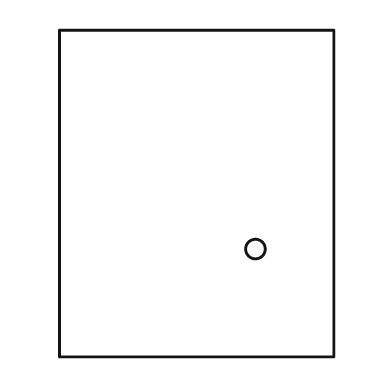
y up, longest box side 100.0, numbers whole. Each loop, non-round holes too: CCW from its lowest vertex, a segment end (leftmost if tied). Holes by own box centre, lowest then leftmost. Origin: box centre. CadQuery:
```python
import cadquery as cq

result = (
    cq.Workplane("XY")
    .moveTo(-42.0, -50.0)
    .lineTo(42.0, -50.0)
    .lineTo(42.0, 50.0)
    .lineTo(-42.0, 50.0)
    .close()
    .moveTo(18.0, -17.0)
    .circle(3.0)
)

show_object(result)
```